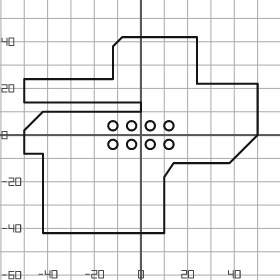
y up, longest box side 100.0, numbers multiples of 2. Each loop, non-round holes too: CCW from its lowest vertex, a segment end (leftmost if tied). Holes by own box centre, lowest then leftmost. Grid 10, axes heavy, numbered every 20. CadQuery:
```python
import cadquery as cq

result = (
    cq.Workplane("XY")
    .moveTo(-42.0, -42.0)
    .lineTo(10.0, -42.0)
    .lineTo(10.0, -18.0)
    .lineTo(14.0, -12.0)
    .lineTo(38.0, -12.0)
    .lineTo(50.0, 0.0)
    .lineTo(50.0, 22.0)
    .lineTo(24.0, 22.0)
    .lineTo(24.0, 42.0)
    .lineTo(-8.0, 42.0)
    .lineTo(-12.0, 38.0)
    .lineTo(-12.0, 24.0)
    .lineTo(-50.0, 24.0)
    .lineTo(-50.0, 14.0)
    .lineTo(0.0, 14.0)
    .lineTo(0.0, 10.0)
    .lineTo(-42.0, 10.0)
    .lineTo(-50.0, 2.0)
    .lineTo(-50.0, -8.0)
    .lineTo(-42.0, -8.0)
    .close()
    .moveTo(-12.0, -4.0)
    .circle(2.0)
    .moveTo(-4.0, -4.0)
    .circle(2.0)
    .moveTo(4.0, -4.0)
    .circle(2.0)
    .moveTo(12.0, -4.0)
    .circle(2.0)
    .moveTo(-12.0, 4.0)
    .circle(2.0)
    .moveTo(-4.0, 4.0)
    .circle(2.0)
    .moveTo(4.0, 4.0)
    .circle(2.0)
    .moveTo(12.0, 4.0)
    .circle(2.0)
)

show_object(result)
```